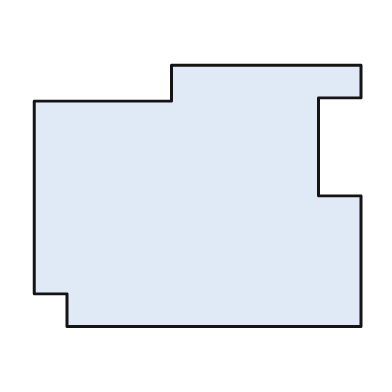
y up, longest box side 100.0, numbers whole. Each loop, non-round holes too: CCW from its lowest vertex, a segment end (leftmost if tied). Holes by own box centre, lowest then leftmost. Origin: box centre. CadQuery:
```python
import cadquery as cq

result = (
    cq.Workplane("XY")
    .moveTo(-40.0, -40.0)
    .lineTo(50.0, -40.0)
    .lineTo(50.0, 0.0)
    .lineTo(37.0, 0.0)
    .lineTo(37.0, 30.0)
    .lineTo(50.0, 30.0)
    .lineTo(50.0, 40.0)
    .lineTo(-8.0, 40.0)
    .lineTo(-8.0, 29.0)
    .lineTo(-50.0, 29.0)
    .lineTo(-50.0, -30.0)
    .lineTo(-40.0, -30.0)
    .close()
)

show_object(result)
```